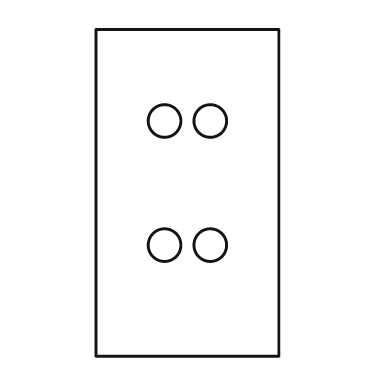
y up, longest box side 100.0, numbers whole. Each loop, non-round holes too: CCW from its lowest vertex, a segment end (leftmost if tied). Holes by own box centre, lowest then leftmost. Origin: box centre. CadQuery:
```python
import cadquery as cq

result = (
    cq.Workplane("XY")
    .moveTo(-28.0, -50.0)
    .lineTo(28.0, -50.0)
    .lineTo(28.0, 50.0)
    .lineTo(-28.0, 50.0)
    .close()
    .moveTo(-7.0, -16.0)
    .circle(5.0)
    .moveTo(7.0, -16.0)
    .circle(5.0)
    .moveTo(-7.0, 22.0)
    .circle(5.0)
    .moveTo(7.0, 22.0)
    .circle(5.0)
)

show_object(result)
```